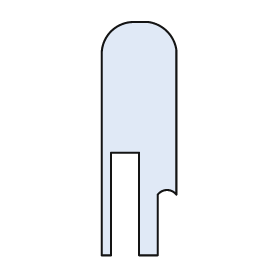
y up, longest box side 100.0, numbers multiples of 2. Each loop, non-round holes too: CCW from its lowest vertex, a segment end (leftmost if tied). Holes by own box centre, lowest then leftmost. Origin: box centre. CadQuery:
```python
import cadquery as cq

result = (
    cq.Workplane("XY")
    .moveTo(-16.0, -50.0)
    .lineTo(-12.0, -50.0)
    .lineTo(-12.0, -6.0)
    .lineTo(0.0, -6.0)
    .lineTo(0.0, -50.0)
    .lineTo(8.0, -50.0)
    .lineTo(8.0, -24.0)
    .threePointArc((12.0, -22.0), (16.0, -24.0))
    .lineTo(16.0, 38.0)
    .threePointArc((12.0, 46.0), (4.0, 50.0))
    .lineTo(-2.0, 50.0)
    .threePointArc((-12.0, 46.0), (-16.0, 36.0))
    .close()
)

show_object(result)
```